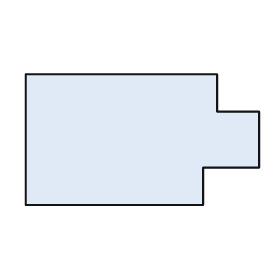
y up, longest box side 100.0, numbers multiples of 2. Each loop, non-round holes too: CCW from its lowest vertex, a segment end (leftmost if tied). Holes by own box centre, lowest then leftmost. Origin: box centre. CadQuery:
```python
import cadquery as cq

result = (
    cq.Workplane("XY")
    .moveTo(-50.0, -28.0)
    .lineTo(26.0, -28.0)
    .lineTo(26.0, -12.0)
    .lineTo(50.0, -12.0)
    .lineTo(50.0, 12.0)
    .lineTo(32.0, 12.0)
    .lineTo(32.0, 28.0)
    .lineTo(-50.0, 28.0)
    .close()
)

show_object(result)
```